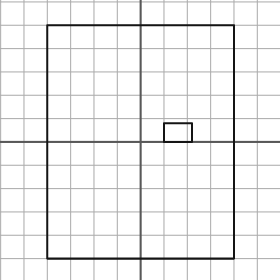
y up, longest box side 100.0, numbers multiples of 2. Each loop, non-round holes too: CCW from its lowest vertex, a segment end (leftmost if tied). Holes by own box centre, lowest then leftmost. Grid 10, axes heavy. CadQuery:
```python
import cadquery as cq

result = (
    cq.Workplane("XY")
    .moveTo(-40.0, -50.0)
    .lineTo(40.0, -50.0)
    .lineTo(40.0, 50.0)
    .lineTo(-40.0, 50.0)
    .close()
    .moveTo(10.0, 0.0)
    .lineTo(22.0, 0.0)
    .lineTo(22.0, 8.0)
    .lineTo(10.0, 8.0)
    .close()
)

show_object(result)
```